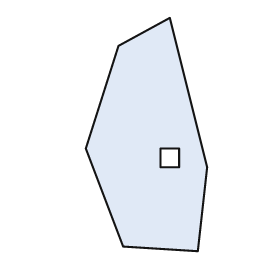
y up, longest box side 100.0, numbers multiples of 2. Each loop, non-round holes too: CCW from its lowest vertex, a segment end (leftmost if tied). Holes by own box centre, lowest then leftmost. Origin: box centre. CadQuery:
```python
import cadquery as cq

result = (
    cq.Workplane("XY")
    .moveTo(22.0, -50.0)
    .lineTo(26.0, -14.0)
    .lineTo(10.0, 50.0)
    .lineTo(-12.0, 38.0)
    .lineTo(-26.0, -6.0)
    .lineTo(-10.0, -48.0)
    .close()
    .moveTo(6.0, -14.0)
    .lineTo(14.0, -14.0)
    .lineTo(14.0, -6.0)
    .lineTo(6.0, -6.0)
    .close()
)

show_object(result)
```